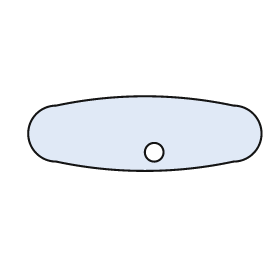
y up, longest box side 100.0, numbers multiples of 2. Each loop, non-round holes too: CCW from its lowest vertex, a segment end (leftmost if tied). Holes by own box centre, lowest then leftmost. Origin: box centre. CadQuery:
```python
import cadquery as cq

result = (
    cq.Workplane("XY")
    .moveTo(-38.0, -12.0)
    .threePointArc((0.0, -16.0), (38.0, -12.0))
    .threePointArc((50.0, 0.0), (38.0, 12.0))
    .threePointArc((0.0, 16.0), (-38.0, 12.0))
    .threePointArc((-50.0, 0.0), (-38.0, -12.0))
    .close()
    .moveTo(4.0, -8.0)
    .circle(4.0)
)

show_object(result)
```